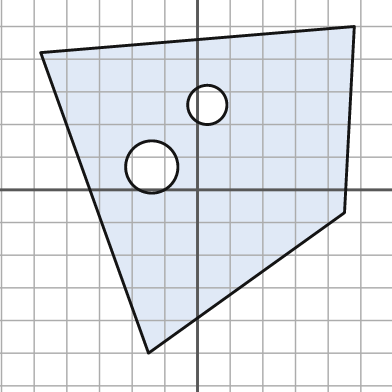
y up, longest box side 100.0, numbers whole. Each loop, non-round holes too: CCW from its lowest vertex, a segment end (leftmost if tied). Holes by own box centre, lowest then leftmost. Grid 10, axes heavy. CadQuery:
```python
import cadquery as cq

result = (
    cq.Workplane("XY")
    .moveTo(-15.0, -50.0)
    .lineTo(45.0, -7.0)
    .lineTo(48.0, 50.0)
    .lineTo(-48.0, 42.0)
    .close()
    .moveTo(-14.0, 7.0)
    .circle(8.0)
    .moveTo(3.0, 26.0)
    .circle(6.0)
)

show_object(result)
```